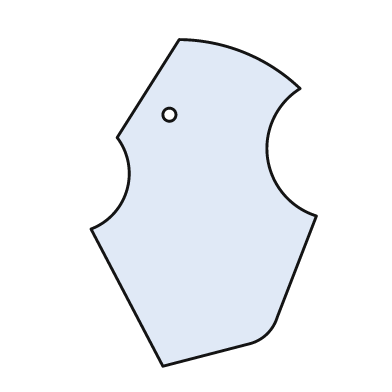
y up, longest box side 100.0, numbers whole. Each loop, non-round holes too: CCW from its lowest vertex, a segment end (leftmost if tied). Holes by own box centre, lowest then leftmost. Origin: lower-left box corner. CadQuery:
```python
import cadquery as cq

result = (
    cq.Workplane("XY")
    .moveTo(22.0, 0.0)
    .lineTo(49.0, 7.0)
    .threePointArc((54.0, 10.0), (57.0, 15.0))
    .lineTo(69.0, 46.0)
    .threePointArc((54.0, 64.0), (64.0, 85.0))
    .threePointArc((47.0, 96.0), (27.0, 100.0))
    .lineTo(8.0, 70.0)
    .threePointArc((11.0, 54.0), (0.0, 42.0))
    .close()
    .moveTo(24.0, 77.0)
    .circle(2.0)
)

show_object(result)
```